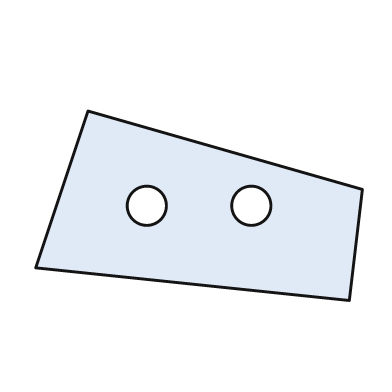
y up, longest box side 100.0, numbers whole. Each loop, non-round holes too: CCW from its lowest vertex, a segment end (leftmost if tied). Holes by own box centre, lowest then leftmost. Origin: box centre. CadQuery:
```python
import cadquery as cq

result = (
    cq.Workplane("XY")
    .moveTo(46.0, -29.0)
    .lineTo(50.0, 5.0)
    .lineTo(-34.0, 29.0)
    .lineTo(-50.0, -19.0)
    .close()
    .moveTo(-16.0, 0.0)
    .circle(6.0)
    .moveTo(16.0, 0.0)
    .circle(6.0)
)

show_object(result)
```